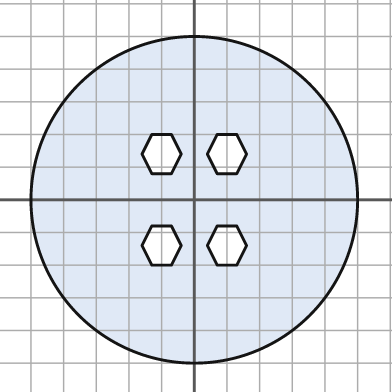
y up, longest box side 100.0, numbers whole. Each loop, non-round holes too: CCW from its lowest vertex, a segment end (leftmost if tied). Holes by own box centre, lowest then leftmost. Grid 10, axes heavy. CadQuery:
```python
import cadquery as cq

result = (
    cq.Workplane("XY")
    .moveTo(0.0, 0.0)
    .circle(50.0)
    .moveTo(-13.0, -20.0)
    .lineTo(-7.0, -20.0)
    .lineTo(-4.0, -14.0)
    .lineTo(-7.0, -8.0)
    .lineTo(-13.0, -8.0)
    .lineTo(-16.0, -14.0)
    .close()
    .moveTo(7.0, -20.0)
    .lineTo(13.0, -20.0)
    .lineTo(16.0, -14.0)
    .lineTo(13.0, -8.0)
    .lineTo(7.0, -8.0)
    .lineTo(4.0, -14.0)
    .close()
    .moveTo(-13.0, 8.0)
    .lineTo(-7.0, 8.0)
    .lineTo(-4.0, 14.0)
    .lineTo(-7.0, 20.0)
    .lineTo(-13.0, 20.0)
    .lineTo(-16.0, 14.0)
    .close()
    .moveTo(7.0, 8.0)
    .lineTo(13.0, 8.0)
    .lineTo(16.0, 14.0)
    .lineTo(13.0, 20.0)
    .lineTo(7.0, 20.0)
    .lineTo(4.0, 14.0)
    .close()
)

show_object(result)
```